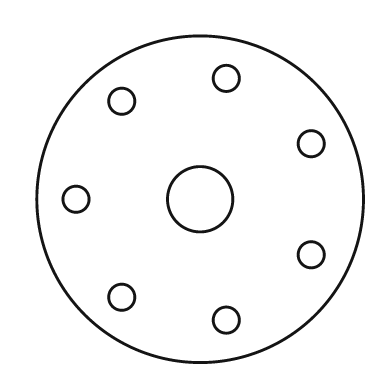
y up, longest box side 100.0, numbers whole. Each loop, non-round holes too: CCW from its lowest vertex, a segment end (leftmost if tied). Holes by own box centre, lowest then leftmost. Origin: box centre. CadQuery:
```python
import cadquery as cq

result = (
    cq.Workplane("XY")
    .moveTo(0.0, 0.0)
    .circle(50.0)
    .moveTo(8.0, -37.0)
    .circle(4.0)
    .moveTo(-24.0, -30.0)
    .circle(4.0)
    .moveTo(34.0, -17.0)
    .circle(4.0)
    .moveTo(-38.0, 0.0)
    .circle(4.0)
    .moveTo(0.0, 0.0)
    .circle(10.0)
    .moveTo(34.0, 17.0)
    .circle(4.0)
    .moveTo(-24.0, 30.0)
    .circle(4.0)
    .moveTo(8.0, 37.0)
    .circle(4.0)
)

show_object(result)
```